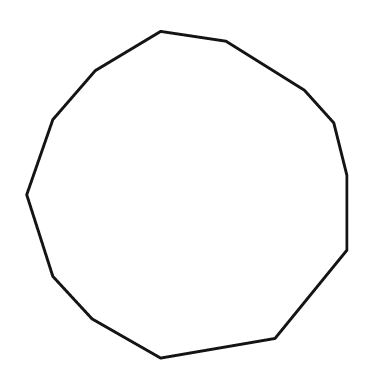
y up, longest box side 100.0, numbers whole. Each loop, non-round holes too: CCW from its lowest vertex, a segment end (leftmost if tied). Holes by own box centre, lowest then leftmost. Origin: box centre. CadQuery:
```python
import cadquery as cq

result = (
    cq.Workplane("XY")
    .moveTo(-8.0, -50.0)
    .lineTo(27.0, -44.0)
    .lineTo(49.0, -17.0)
    .lineTo(49.0, 6.0)
    .lineTo(45.0, 22.0)
    .lineTo(36.0, 32.0)
    .lineTo(12.0, 47.0)
    .lineTo(-8.0, 50.0)
    .lineTo(-28.0, 38.0)
    .lineTo(-41.0, 23.0)
    .lineTo(-49.0, 0.0)
    .lineTo(-41.0, -25.0)
    .lineTo(-29.0, -38.0)
    .close()
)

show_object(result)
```